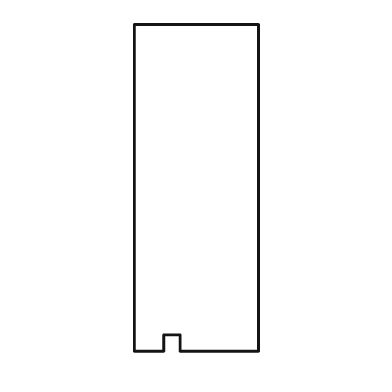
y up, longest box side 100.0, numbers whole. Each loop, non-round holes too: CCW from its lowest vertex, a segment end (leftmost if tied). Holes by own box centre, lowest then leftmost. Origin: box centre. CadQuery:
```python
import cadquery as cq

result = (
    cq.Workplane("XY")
    .moveTo(-19.0, -50.0)
    .lineTo(-10.0, -50.0)
    .lineTo(-10.0, -45.0)
    .lineTo(-5.0, -45.0)
    .lineTo(-5.0, -50.0)
    .lineTo(19.0, -50.0)
    .lineTo(19.0, 50.0)
    .lineTo(-19.0, 50.0)
    .close()
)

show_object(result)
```